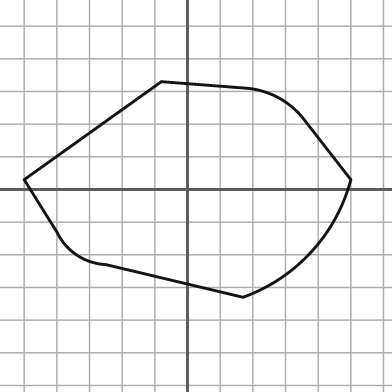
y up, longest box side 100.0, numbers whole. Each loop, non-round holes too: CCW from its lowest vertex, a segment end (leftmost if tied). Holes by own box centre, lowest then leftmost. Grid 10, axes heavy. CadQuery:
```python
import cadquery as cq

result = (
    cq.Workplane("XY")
    .moveTo(17.0, -33.0)
    .threePointArc((38.0, -19.0), (50.0, 3.0))
    .lineTo(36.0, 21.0)
    .threePointArc((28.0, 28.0), (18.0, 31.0))
    .lineTo(-8.0, 33.0)
    .lineTo(-50.0, 3.0)
    .lineTo(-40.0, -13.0)
    .threePointArc((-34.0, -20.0), (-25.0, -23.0))
    .close()
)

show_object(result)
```